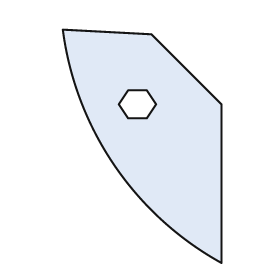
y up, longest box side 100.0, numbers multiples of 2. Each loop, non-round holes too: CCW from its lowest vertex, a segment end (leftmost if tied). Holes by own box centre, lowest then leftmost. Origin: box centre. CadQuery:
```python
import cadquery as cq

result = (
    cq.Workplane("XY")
    .moveTo(34.0, -50.0)
    .lineTo(34.0, 18.0)
    .lineTo(4.0, 48.0)
    .lineTo(-34.0, 50.0)
    .threePointArc((-12.0, -8.0), (34.0, -50.0))
    .close()
    .moveTo(-6.0, 12.0)
    .lineTo(2.0, 12.0)
    .lineTo(6.0, 18.0)
    .lineTo(2.0, 24.0)
    .lineTo(-6.0, 24.0)
    .lineTo(-10.0, 18.0)
    .close()
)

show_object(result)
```